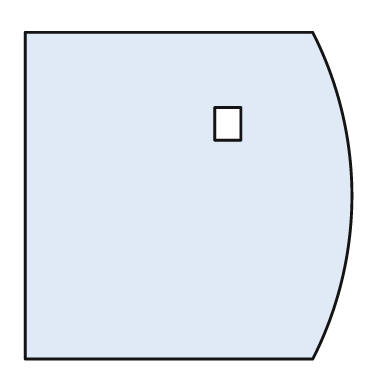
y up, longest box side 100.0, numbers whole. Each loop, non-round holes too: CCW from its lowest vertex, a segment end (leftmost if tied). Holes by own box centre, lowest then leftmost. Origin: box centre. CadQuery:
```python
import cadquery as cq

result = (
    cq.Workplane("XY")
    .moveTo(-50.0, -50.0)
    .lineTo(38.0, -50.0)
    .threePointArc((50.0, 0.0), (38.0, 50.0))
    .lineTo(-50.0, 50.0)
    .close()
    .moveTo(8.0, 17.0)
    .lineTo(16.0, 17.0)
    .lineTo(16.0, 27.0)
    .lineTo(8.0, 27.0)
    .close()
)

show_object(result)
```